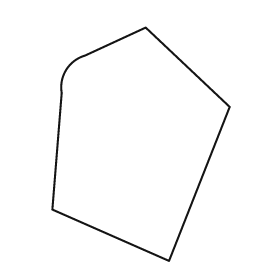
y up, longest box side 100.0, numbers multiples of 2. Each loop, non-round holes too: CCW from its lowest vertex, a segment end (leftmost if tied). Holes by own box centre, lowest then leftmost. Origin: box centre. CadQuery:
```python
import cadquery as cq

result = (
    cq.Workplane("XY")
    .moveTo(12.0, -50.0)
    .lineTo(38.0, 16.0)
    .lineTo(2.0, 50.0)
    .lineTo(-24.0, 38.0)
    .threePointArc((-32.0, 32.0), (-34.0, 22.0))
    .lineTo(-38.0, -28.0)
    .close()
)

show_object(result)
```